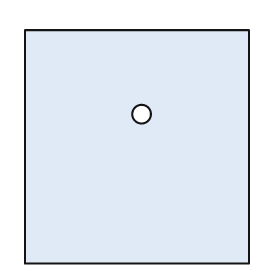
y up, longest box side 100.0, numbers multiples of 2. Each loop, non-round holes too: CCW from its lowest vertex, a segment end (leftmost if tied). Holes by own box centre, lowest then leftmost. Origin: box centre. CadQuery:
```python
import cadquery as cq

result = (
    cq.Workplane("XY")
    .moveTo(-48.0, -50.0)
    .lineTo(48.0, -50.0)
    .lineTo(48.0, 50.0)
    .lineTo(-48.0, 50.0)
    .close()
    .moveTo(2.0, 14.0)
    .circle(4.0)
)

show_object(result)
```